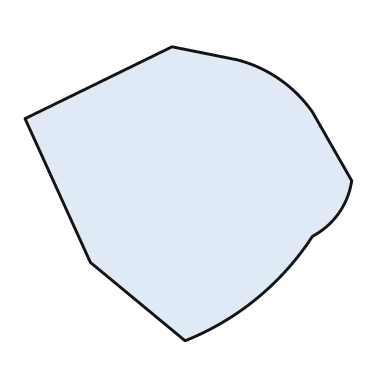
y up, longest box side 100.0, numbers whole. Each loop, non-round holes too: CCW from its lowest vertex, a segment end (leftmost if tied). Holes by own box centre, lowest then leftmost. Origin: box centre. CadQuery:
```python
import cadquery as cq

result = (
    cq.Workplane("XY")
    .moveTo(-1.0, -45.0)
    .threePointArc((21.0, -32.0), (38.0, -13.0))
    .threePointArc((46.0, -6.0), (50.0, 4.0))
    .lineTo(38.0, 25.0)
    .threePointArc((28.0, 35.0), (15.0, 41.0))
    .lineTo(-5.0, 45.0)
    .lineTo(-50.0, 23.0)
    .lineTo(-30.0, -21.0)
    .close()
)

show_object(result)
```